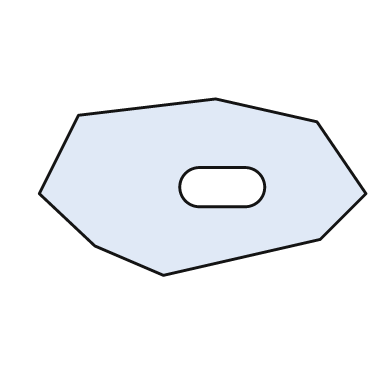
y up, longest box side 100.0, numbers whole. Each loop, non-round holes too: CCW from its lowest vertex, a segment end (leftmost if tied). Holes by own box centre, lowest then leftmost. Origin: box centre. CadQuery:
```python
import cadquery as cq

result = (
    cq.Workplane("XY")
    .moveTo(-12.0, -27.0)
    .lineTo(36.0, -16.0)
    .lineTo(50.0, -2.0)
    .lineTo(35.0, 20.0)
    .lineTo(4.0, 27.0)
    .lineTo(-38.0, 22.0)
    .lineTo(-50.0, -2.0)
    .lineTo(-33.0, -18.0)
    .close()
    .moveTo(-1.0, -6.0)
    .lineTo(13.0, -6.0)
    .threePointArc((19.0, 0.0), (13.0, 6.0))
    .lineTo(-1.0, 6.0)
    .threePointArc((-7.0, 0.0), (-1.0, -6.0))
    .close()
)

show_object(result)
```